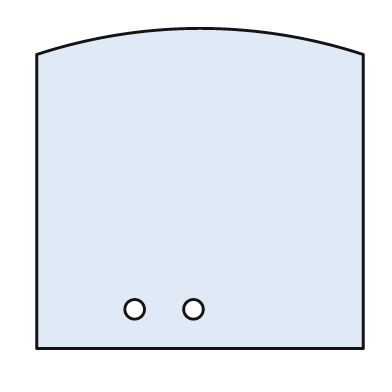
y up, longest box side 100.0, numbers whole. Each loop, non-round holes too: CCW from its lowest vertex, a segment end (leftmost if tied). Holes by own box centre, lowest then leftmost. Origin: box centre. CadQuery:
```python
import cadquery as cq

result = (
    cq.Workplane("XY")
    .moveTo(-50.0, -49.0)
    .lineTo(50.0, -49.0)
    .lineTo(50.0, 41.0)
    .threePointArc((0.0, 49.0), (-50.0, 41.0))
    .close()
    .moveTo(-20.0, -37.0)
    .circle(3.0)
    .moveTo(-2.0, -37.0)
    .circle(3.0)
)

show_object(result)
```